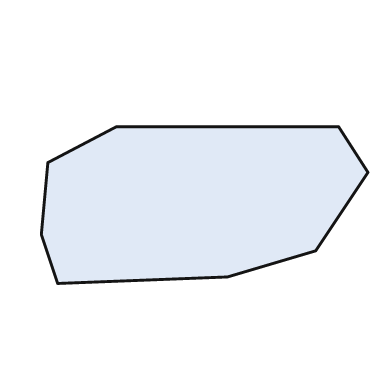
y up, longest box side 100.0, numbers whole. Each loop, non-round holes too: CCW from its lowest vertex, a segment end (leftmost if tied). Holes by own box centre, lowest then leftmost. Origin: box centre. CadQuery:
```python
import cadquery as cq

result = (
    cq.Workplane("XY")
    .moveTo(-45.0, -24.0)
    .lineTo(7.0, -22.0)
    .lineTo(34.0, -14.0)
    .lineTo(50.0, 10.0)
    .lineTo(41.0, 24.0)
    .lineTo(-27.0, 24.0)
    .lineTo(-48.0, 13.0)
    .lineTo(-50.0, -9.0)
    .close()
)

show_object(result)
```